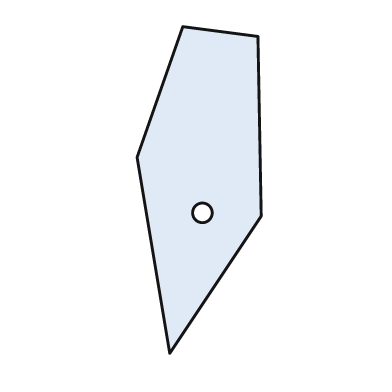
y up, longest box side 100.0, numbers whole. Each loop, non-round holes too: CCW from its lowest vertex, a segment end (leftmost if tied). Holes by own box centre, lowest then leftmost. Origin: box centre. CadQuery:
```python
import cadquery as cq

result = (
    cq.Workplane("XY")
    .moveTo(-9.0, -50.0)
    .lineTo(19.0, -8.0)
    .lineTo(18.0, 47.0)
    .lineTo(-5.0, 50.0)
    .lineTo(-19.0, 10.0)
    .close()
    .moveTo(1.0, -7.0)
    .circle(3.0)
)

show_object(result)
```